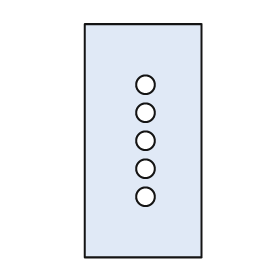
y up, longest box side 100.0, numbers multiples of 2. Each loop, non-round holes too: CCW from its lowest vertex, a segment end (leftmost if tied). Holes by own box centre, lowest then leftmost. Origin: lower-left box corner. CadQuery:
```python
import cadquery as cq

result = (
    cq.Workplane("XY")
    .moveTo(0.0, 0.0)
    .lineTo(50.0, 0.0)
    .lineTo(50.0, 100.0)
    .lineTo(0.0, 100.0)
    .close()
    .moveTo(26.0, 26.0)
    .circle(4.0)
    .moveTo(26.0, 38.0)
    .circle(4.0)
    .moveTo(26.0, 50.0)
    .circle(4.0)
    .moveTo(26.0, 62.0)
    .circle(4.0)
    .moveTo(26.0, 74.0)
    .circle(4.0)
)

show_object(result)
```